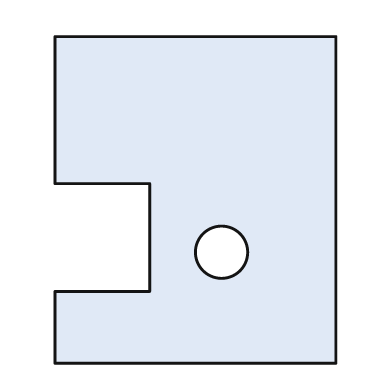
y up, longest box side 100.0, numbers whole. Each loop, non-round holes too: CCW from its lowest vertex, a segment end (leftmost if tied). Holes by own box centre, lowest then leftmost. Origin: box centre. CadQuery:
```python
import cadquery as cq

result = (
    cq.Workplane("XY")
    .moveTo(-43.0, -50.0)
    .lineTo(43.0, -50.0)
    .lineTo(43.0, 50.0)
    .lineTo(-43.0, 50.0)
    .lineTo(-43.0, 5.0)
    .lineTo(-14.0, 5.0)
    .lineTo(-14.0, -28.0)
    .lineTo(-43.0, -28.0)
    .close()
    .moveTo(8.0, -16.0)
    .circle(8.0)
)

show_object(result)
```